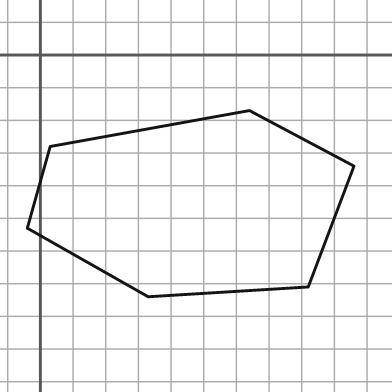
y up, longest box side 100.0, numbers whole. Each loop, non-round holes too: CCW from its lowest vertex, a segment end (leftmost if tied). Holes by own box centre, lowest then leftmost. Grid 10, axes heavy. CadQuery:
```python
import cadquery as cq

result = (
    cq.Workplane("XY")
    .moveTo(33.0, -74.0)
    .lineTo(82.0, -71.0)
    .lineTo(96.0, -34.0)
    .lineTo(64.0, -17.0)
    .lineTo(3.0, -28.0)
    .lineTo(-4.0, -53.0)
    .close()
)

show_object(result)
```